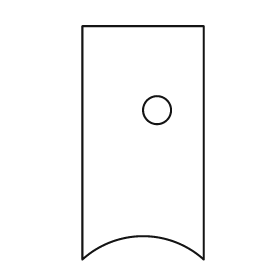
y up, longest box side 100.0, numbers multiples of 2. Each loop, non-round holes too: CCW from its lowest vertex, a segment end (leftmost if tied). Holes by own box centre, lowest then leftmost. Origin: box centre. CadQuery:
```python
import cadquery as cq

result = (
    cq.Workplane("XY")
    .moveTo(-26.0, -50.0)
    .threePointArc((0.0, -40.0), (26.0, -50.0))
    .lineTo(26.0, 50.0)
    .lineTo(-26.0, 50.0)
    .close()
    .moveTo(6.0, 14.0)
    .circle(6.0)
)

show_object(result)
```